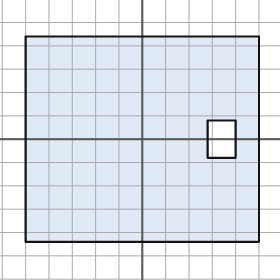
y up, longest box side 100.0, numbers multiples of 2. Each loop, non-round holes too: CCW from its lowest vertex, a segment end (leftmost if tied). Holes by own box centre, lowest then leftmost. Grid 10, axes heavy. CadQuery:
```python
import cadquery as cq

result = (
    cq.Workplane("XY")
    .moveTo(-50.0, -44.0)
    .lineTo(50.0, -44.0)
    .lineTo(50.0, 44.0)
    .lineTo(-50.0, 44.0)
    .close()
    .moveTo(28.0, -8.0)
    .lineTo(40.0, -8.0)
    .lineTo(40.0, 8.0)
    .lineTo(28.0, 8.0)
    .close()
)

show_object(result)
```